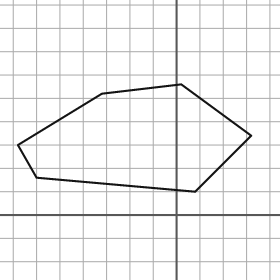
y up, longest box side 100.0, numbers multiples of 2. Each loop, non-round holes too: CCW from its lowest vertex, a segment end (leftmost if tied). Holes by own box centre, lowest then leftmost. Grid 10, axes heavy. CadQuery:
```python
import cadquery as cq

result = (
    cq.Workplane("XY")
    .moveTo(8.0, 10.0)
    .lineTo(32.0, 34.0)
    .lineTo(2.0, 56.0)
    .lineTo(-32.0, 52.0)
    .lineTo(-68.0, 30.0)
    .lineTo(-60.0, 16.0)
    .close()
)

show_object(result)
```